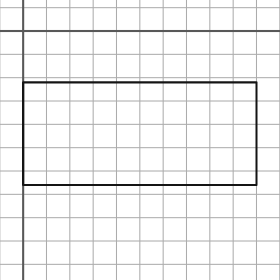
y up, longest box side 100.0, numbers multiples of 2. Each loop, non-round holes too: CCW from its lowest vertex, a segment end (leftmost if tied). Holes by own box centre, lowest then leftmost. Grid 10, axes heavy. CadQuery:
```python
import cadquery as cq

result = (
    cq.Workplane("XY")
    .moveTo(0.0, -66.0)
    .lineTo(100.0, -66.0)
    .lineTo(100.0, -22.0)
    .lineTo(0.0, -22.0)
    .close()
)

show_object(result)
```